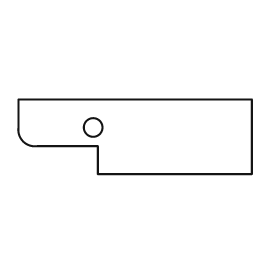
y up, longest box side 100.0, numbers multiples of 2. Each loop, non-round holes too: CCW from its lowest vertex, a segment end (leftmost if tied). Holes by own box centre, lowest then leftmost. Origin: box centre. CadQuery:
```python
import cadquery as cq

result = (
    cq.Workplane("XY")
    .moveTo(-16.0, -16.0)
    .lineTo(50.0, -16.0)
    .lineTo(50.0, 16.0)
    .lineTo(-50.0, 16.0)
    .lineTo(-50.0, 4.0)
    .threePointArc((-48.0, -2.0), (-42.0, -4.0))
    .lineTo(-16.0, -4.0)
    .close()
    .moveTo(-18.0, 4.0)
    .circle(4.0)
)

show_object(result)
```